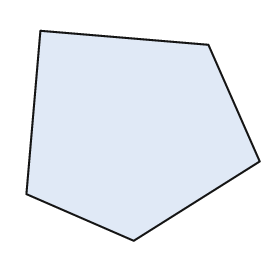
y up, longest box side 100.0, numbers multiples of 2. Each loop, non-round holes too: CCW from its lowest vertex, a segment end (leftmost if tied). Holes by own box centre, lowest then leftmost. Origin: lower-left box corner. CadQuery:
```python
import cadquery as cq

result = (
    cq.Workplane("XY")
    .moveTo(46.0, 0.0)
    .lineTo(100.0, 34.0)
    .lineTo(78.0, 84.0)
    .lineTo(6.0, 90.0)
    .lineTo(0.0, 20.0)
    .close()
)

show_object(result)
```